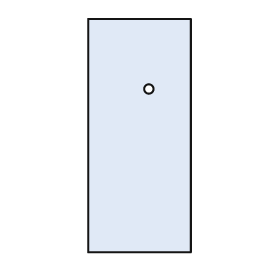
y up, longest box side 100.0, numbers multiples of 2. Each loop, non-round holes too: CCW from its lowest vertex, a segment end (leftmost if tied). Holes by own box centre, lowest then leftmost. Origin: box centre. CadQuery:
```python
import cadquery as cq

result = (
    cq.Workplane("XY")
    .moveTo(-22.0, -50.0)
    .lineTo(22.0, -50.0)
    .lineTo(22.0, 50.0)
    .lineTo(-22.0, 50.0)
    .close()
    .moveTo(4.0, 20.0)
    .circle(2.0)
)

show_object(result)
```